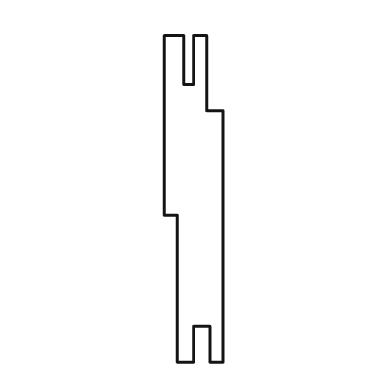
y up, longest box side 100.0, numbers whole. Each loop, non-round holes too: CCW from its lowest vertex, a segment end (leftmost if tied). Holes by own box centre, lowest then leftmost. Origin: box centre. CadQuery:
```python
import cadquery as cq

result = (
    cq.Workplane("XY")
    .moveTo(-5.0, -50.0)
    .lineTo(0.0, -50.0)
    .lineTo(0.0, -39.0)
    .lineTo(5.0, -39.0)
    .lineTo(5.0, -50.0)
    .lineTo(9.0, -50.0)
    .lineTo(9.0, 27.0)
    .lineTo(4.0, 27.0)
    .lineTo(4.0, 50.0)
    .lineTo(0.0, 50.0)
    .lineTo(0.0, 35.0)
    .lineTo(-3.0, 35.0)
    .lineTo(-3.0, 50.0)
    .lineTo(-9.0, 50.0)
    .lineTo(-9.0, -5.0)
    .lineTo(-5.0, -5.0)
    .close()
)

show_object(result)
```